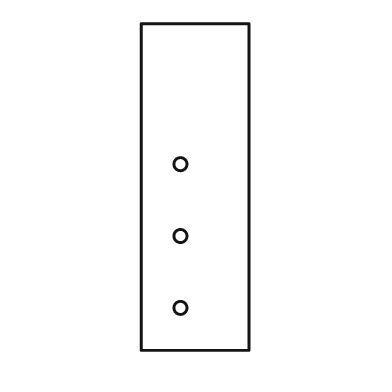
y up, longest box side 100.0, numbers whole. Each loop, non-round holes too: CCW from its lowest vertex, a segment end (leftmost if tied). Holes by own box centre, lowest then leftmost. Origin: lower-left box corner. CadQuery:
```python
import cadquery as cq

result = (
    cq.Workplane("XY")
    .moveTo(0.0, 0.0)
    .lineTo(33.0, 0.0)
    .lineTo(33.0, 100.0)
    .lineTo(0.0, 100.0)
    .close()
    .moveTo(12.0, 13.0)
    .circle(2.0)
    .moveTo(12.0, 35.0)
    .circle(2.0)
    .moveTo(12.0, 57.0)
    .circle(2.0)
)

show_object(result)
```